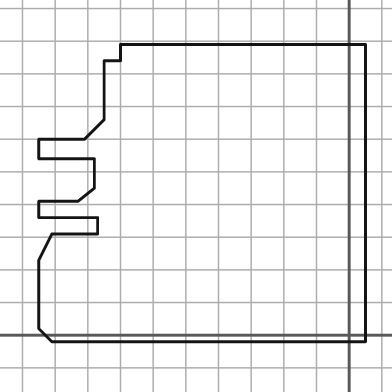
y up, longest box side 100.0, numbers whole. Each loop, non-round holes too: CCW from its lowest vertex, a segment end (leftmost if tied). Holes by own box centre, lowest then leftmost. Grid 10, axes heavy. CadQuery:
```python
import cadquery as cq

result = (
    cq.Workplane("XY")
    .moveTo(-91.0, -2.0)
    .lineTo(5.0, -2.0)
    .lineTo(5.0, 89.0)
    .lineTo(-70.0, 89.0)
    .lineTo(-70.0, 84.0)
    .lineTo(-75.0, 84.0)
    .lineTo(-75.0, 66.0)
    .lineTo(-81.0, 60.0)
    .lineTo(-95.0, 60.0)
    .lineTo(-95.0, 54.0)
    .lineTo(-78.0, 54.0)
    .lineTo(-78.0, 45.0)
    .lineTo(-83.0, 41.0)
    .lineTo(-95.0, 41.0)
    .lineTo(-95.0, 36.0)
    .lineTo(-77.0, 36.0)
    .lineTo(-77.0, 31.0)
    .lineTo(-91.0, 31.0)
    .lineTo(-95.0, 23.0)
    .lineTo(-95.0, 2.0)
    .close()
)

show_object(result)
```